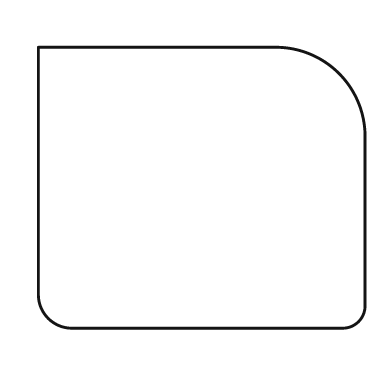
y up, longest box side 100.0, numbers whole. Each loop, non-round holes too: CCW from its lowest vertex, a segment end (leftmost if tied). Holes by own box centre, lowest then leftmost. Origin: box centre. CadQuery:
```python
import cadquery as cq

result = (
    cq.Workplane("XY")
    .moveTo(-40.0, -43.0)
    .lineTo(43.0, -43.0)
    .threePointArc((48.0, -41.0), (50.0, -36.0))
    .lineTo(50.0, 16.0)
    .threePointArc((42.0, 35.0), (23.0, 43.0))
    .lineTo(-50.0, 43.0)
    .lineTo(-50.0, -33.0)
    .threePointArc((-47.0, -40.0), (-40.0, -43.0))
    .close()
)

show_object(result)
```